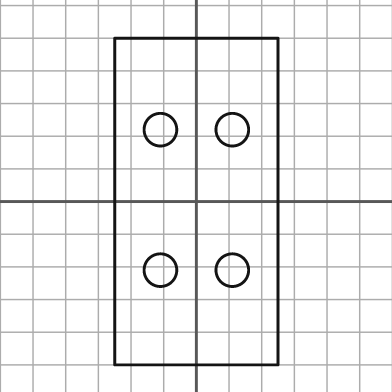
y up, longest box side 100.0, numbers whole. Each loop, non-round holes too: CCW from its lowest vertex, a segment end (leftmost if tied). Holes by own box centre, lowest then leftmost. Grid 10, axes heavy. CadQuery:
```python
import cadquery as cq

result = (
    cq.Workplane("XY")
    .moveTo(-25.0, -50.0)
    .lineTo(25.0, -50.0)
    .lineTo(25.0, 50.0)
    .lineTo(-25.0, 50.0)
    .close()
    .moveTo(-11.0, -21.0)
    .circle(5.0)
    .moveTo(11.0, -21.0)
    .circle(5.0)
    .moveTo(-11.0, 22.0)
    .circle(5.0)
    .moveTo(11.0, 22.0)
    .circle(5.0)
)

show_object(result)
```